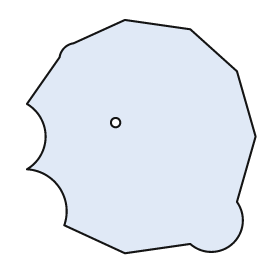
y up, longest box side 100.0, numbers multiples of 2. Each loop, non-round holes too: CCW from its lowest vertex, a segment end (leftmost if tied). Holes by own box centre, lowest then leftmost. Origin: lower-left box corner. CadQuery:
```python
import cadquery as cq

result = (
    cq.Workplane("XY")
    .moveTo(42.0, 0.0)
    .lineTo(70.0, 4.0)
    .threePointArc((88.0, 4.0), (90.0, 22.0))
    .lineTo(98.0, 50.0)
    .lineTo(90.0, 78.0)
    .lineTo(70.0, 96.0)
    .lineTo(42.0, 100.0)
    .lineTo(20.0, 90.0)
    .threePointArc((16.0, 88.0), (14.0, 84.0))
    .lineTo(0.0, 64.0)
    .threePointArc((8.0, 50.0), (0.0, 36.0))
    .threePointArc((14.0, 28.0), (16.0, 12.0))
    .close()
    .moveTo(38.0, 56.0)
    .circle(2.0)
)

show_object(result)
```